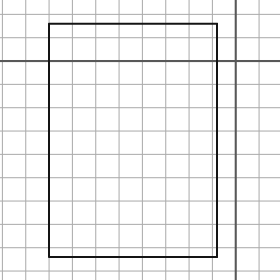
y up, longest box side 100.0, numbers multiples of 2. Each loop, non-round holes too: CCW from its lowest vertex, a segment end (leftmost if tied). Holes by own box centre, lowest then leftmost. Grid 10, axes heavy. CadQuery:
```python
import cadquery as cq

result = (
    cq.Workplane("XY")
    .moveTo(-80.0, -84.0)
    .lineTo(-8.0, -84.0)
    .lineTo(-8.0, 16.0)
    .lineTo(-80.0, 16.0)
    .close()
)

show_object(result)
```